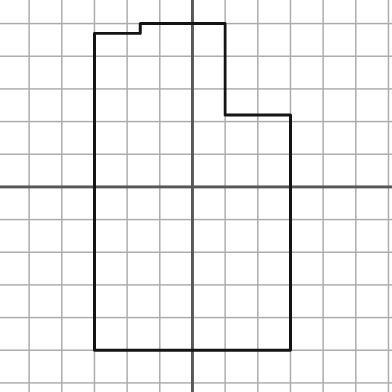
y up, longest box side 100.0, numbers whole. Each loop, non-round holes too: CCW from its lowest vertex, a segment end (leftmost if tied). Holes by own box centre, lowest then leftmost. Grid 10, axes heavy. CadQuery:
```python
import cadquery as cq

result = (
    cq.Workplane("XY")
    .moveTo(-30.0, -50.0)
    .lineTo(30.0, -50.0)
    .lineTo(30.0, 22.0)
    .lineTo(10.0, 22.0)
    .lineTo(10.0, 50.0)
    .lineTo(-16.0, 50.0)
    .lineTo(-16.0, 47.0)
    .lineTo(-30.0, 47.0)
    .close()
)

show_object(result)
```